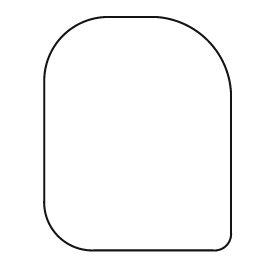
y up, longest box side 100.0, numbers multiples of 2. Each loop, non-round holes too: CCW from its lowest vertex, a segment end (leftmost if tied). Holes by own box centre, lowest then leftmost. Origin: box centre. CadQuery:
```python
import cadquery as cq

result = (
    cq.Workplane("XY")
    .moveTo(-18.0, -50.0)
    .lineTo(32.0, -50.0)
    .threePointArc((38.0, -48.0), (40.0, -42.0))
    .lineTo(40.0, 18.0)
    .threePointArc((30.0, 40.0), (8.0, 50.0))
    .lineTo(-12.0, 50.0)
    .threePointArc((-32.0, 42.0), (-40.0, 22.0))
    .lineTo(-40.0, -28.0)
    .threePointArc((-34.0, -44.0), (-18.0, -50.0))
    .close()
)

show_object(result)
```